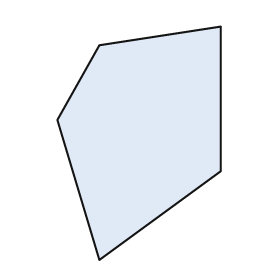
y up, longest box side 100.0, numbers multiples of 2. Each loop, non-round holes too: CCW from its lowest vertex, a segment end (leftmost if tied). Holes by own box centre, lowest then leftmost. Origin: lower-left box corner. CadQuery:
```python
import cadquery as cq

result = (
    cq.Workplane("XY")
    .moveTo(18.0, 0.0)
    .lineTo(70.0, 38.0)
    .lineTo(70.0, 100.0)
    .lineTo(18.0, 92.0)
    .lineTo(0.0, 60.0)
    .close()
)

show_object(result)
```